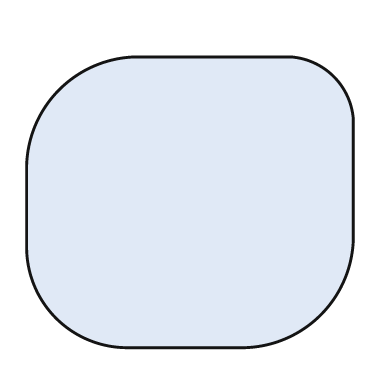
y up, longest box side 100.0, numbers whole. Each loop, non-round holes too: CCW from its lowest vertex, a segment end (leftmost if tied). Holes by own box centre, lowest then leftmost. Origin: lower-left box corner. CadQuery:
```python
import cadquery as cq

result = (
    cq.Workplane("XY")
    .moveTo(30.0, 0.0)
    .lineTo(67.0, 0.0)
    .threePointArc((90.0, 10.0), (100.0, 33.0))
    .lineTo(100.0, 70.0)
    .threePointArc((94.0, 83.0), (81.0, 89.0))
    .lineTo(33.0, 89.0)
    .threePointArc((10.0, 79.0), (0.0, 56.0))
    .lineTo(0.0, 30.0)
    .threePointArc((9.0, 9.0), (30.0, 0.0))
    .close()
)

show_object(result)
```